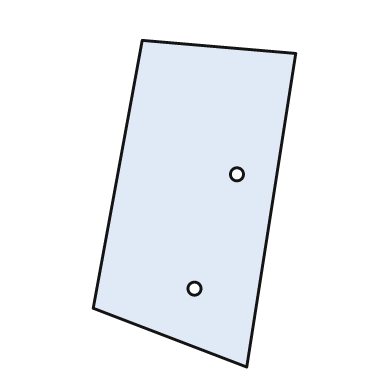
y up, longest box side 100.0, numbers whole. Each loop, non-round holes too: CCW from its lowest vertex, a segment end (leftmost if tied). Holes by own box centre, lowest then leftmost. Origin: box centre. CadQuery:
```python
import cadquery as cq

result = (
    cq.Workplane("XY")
    .moveTo(16.0, -50.0)
    .lineTo(31.0, 46.0)
    .lineTo(-16.0, 50.0)
    .lineTo(-31.0, -32.0)
    .close()
    .moveTo(0.0, -26.0)
    .circle(2.0)
    .moveTo(13.0, 9.0)
    .circle(2.0)
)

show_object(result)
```